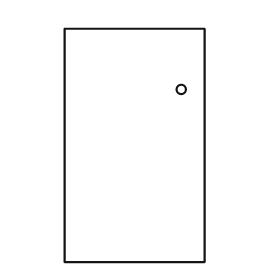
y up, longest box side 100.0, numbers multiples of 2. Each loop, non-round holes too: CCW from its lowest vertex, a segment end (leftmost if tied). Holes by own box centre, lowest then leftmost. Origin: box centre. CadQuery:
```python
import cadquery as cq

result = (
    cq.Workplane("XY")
    .moveTo(-30.0, -50.0)
    .lineTo(30.0, -50.0)
    .lineTo(30.0, 50.0)
    .lineTo(-30.0, 50.0)
    .close()
    .moveTo(20.0, 24.0)
    .circle(2.0)
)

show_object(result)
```